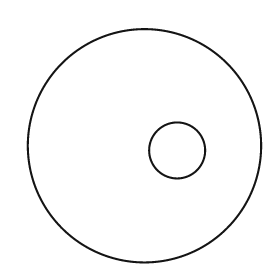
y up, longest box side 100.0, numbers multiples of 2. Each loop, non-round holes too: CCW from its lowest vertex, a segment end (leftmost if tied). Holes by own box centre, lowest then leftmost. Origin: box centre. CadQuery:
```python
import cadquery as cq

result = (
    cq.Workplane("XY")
    .moveTo(0.0, 0.0)
    .circle(50.0)
    .moveTo(14.0, -2.0)
    .circle(12.0)
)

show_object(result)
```